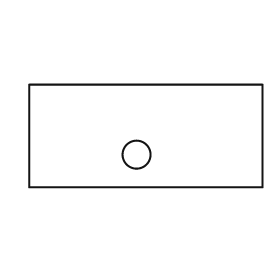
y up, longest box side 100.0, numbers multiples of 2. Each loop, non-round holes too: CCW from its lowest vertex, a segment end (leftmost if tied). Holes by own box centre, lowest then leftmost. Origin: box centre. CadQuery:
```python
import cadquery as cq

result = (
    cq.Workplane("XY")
    .moveTo(-50.0, -22.0)
    .lineTo(50.0, -22.0)
    .lineTo(50.0, 22.0)
    .lineTo(-50.0, 22.0)
    .close()
    .moveTo(-4.0, -8.0)
    .circle(6.0)
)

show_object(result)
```